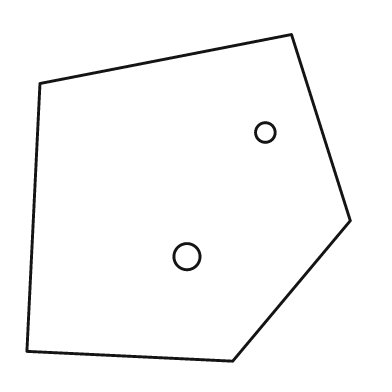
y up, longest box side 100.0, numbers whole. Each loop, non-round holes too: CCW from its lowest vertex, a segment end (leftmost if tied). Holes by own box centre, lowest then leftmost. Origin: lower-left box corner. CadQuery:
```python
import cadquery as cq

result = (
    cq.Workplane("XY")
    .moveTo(63.0, 0.0)
    .lineTo(99.0, 43.0)
    .lineTo(81.0, 100.0)
    .lineTo(4.0, 85.0)
    .lineTo(0.0, 3.0)
    .close()
    .moveTo(49.0, 32.0)
    .circle(4.0)
    .moveTo(73.0, 70.0)
    .circle(3.0)
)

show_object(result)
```